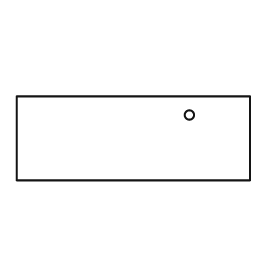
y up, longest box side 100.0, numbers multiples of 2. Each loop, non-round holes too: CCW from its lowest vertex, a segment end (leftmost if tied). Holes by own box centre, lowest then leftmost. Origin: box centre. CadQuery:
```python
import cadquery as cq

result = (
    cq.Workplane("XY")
    .moveTo(-50.0, -18.0)
    .lineTo(50.0, -18.0)
    .lineTo(50.0, 18.0)
    .lineTo(-50.0, 18.0)
    .close()
    .moveTo(24.0, 10.0)
    .circle(2.0)
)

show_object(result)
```